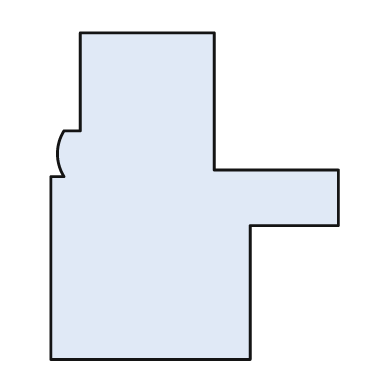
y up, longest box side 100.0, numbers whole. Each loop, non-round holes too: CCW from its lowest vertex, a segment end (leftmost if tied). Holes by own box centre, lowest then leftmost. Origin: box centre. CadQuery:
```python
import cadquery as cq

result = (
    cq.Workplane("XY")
    .moveTo(-44.0, -50.0)
    .lineTo(17.0, -50.0)
    .lineTo(17.0, -9.0)
    .lineTo(44.0, -9.0)
    .lineTo(44.0, 8.0)
    .lineTo(6.0, 8.0)
    .lineTo(6.0, 50.0)
    .lineTo(-35.0, 50.0)
    .lineTo(-35.0, 20.0)
    .lineTo(-40.0, 20.0)
    .threePointArc((-42.0, 13.0), (-40.0, 6.0))
    .lineTo(-44.0, 6.0)
    .close()
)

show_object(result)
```